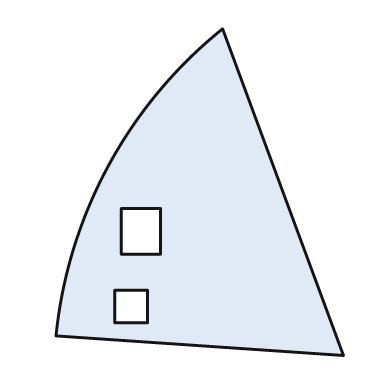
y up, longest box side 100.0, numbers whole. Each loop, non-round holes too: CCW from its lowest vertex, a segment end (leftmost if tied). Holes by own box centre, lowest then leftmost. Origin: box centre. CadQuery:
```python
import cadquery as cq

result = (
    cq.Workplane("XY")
    .moveTo(44.0, -50.0)
    .lineTo(7.0, 50.0)
    .threePointArc((-28.0, 8.0), (-44.0, -44.0))
    .close()
    .moveTo(-26.0, -40.0)
    .lineTo(-16.0, -40.0)
    .lineTo(-16.0, -30.0)
    .lineTo(-26.0, -30.0)
    .close()
    .moveTo(-24.0, -19.0)
    .lineTo(-12.0, -19.0)
    .lineTo(-12.0, -5.0)
    .lineTo(-24.0, -5.0)
    .close()
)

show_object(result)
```